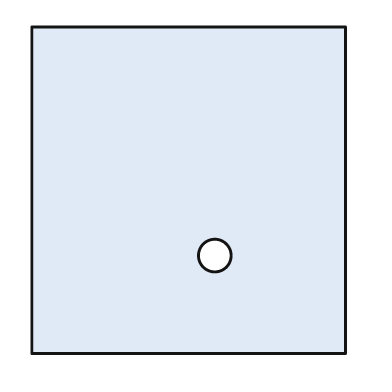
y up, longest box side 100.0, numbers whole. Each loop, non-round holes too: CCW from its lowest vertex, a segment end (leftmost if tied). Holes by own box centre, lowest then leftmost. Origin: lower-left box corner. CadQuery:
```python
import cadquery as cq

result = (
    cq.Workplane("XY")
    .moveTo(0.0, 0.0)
    .lineTo(96.0, 0.0)
    .lineTo(96.0, 100.0)
    .lineTo(0.0, 100.0)
    .close()
    .moveTo(56.0, 30.0)
    .circle(5.0)
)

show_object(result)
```